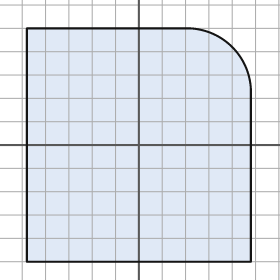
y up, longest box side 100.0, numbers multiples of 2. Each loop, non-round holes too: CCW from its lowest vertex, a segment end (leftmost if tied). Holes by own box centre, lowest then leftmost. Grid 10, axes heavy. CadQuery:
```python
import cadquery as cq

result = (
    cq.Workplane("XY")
    .moveTo(-48.0, -50.0)
    .lineTo(48.0, -50.0)
    .lineTo(48.0, 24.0)
    .threePointArc((40.0, 42.0), (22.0, 50.0))
    .lineTo(-48.0, 50.0)
    .close()
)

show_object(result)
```